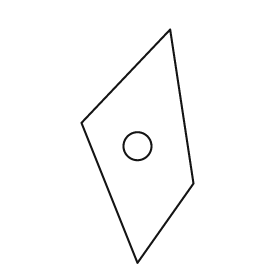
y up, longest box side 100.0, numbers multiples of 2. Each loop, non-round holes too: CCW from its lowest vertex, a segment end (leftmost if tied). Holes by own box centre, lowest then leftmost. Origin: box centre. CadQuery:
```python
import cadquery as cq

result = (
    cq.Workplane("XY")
    .moveTo(0.0, -50.0)
    .lineTo(24.0, -16.0)
    .lineTo(14.0, 50.0)
    .lineTo(-24.0, 10.0)
    .close()
    .moveTo(0.0, 0.0)
    .circle(6.0)
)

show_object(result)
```